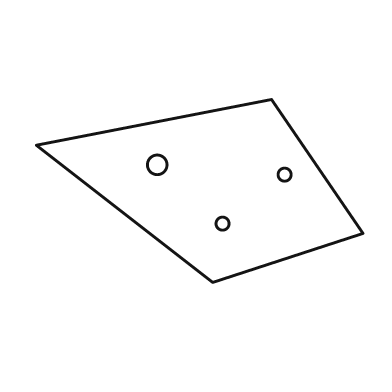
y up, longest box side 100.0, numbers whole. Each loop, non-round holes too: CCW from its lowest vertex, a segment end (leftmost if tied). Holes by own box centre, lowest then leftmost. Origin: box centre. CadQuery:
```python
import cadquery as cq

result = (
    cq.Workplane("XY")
    .moveTo(4.0, -28.0)
    .lineTo(50.0, -13.0)
    .lineTo(22.0, 28.0)
    .lineTo(-50.0, 14.0)
    .close()
    .moveTo(7.0, -10.0)
    .circle(2.0)
    .moveTo(26.0, 5.0)
    .circle(2.0)
    .moveTo(-13.0, 8.0)
    .circle(3.0)
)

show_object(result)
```